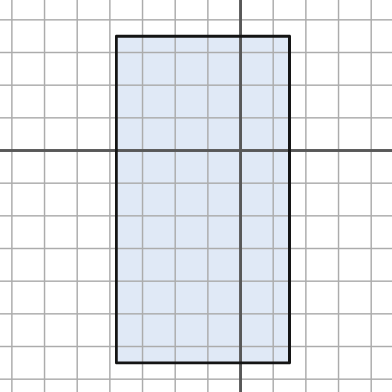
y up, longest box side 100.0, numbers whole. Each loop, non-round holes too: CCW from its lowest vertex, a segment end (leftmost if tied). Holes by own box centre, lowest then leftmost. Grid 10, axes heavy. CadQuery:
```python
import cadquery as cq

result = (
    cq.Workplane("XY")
    .moveTo(-38.0, -65.0)
    .lineTo(15.0, -65.0)
    .lineTo(15.0, 35.0)
    .lineTo(-38.0, 35.0)
    .close()
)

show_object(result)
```